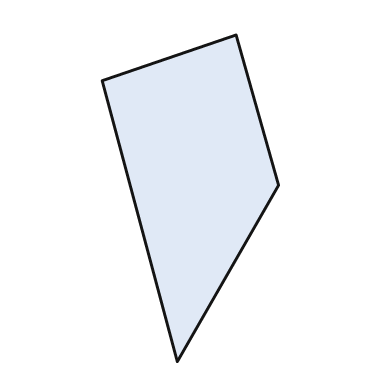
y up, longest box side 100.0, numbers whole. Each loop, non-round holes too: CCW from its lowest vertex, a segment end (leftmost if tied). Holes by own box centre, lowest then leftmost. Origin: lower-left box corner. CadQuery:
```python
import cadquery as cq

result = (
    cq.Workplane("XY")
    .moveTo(23.0, 0.0)
    .lineTo(54.0, 54.0)
    .lineTo(41.0, 100.0)
    .lineTo(0.0, 86.0)
    .close()
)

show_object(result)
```